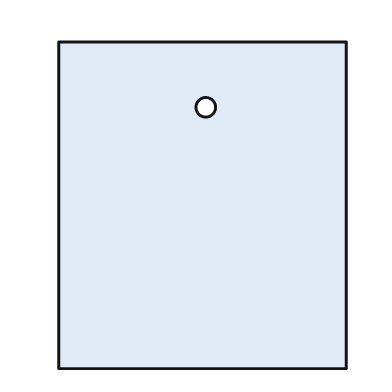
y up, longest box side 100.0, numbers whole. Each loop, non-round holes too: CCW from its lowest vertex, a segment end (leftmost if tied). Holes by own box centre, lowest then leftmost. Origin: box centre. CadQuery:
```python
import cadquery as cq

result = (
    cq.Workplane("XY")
    .moveTo(-44.0, -50.0)
    .lineTo(44.0, -50.0)
    .lineTo(44.0, 50.0)
    .lineTo(-44.0, 50.0)
    .close()
    .moveTo(1.0, 30.0)
    .circle(3.0)
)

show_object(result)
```